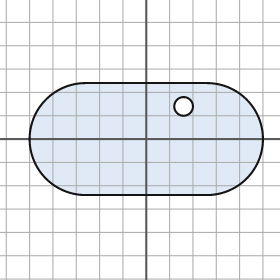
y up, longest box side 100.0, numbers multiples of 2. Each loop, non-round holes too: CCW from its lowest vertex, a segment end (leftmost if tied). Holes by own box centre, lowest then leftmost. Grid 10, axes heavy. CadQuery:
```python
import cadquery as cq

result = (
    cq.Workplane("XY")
    .moveTo(-26.0, -24.0)
    .lineTo(26.0, -24.0)
    .threePointArc((50.0, 0.0), (26.0, 24.0))
    .lineTo(-26.0, 24.0)
    .threePointArc((-50.0, 0.0), (-26.0, -24.0))
    .close()
    .moveTo(16.0, 14.0)
    .circle(4.0)
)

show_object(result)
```